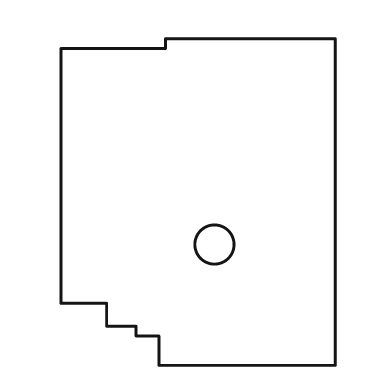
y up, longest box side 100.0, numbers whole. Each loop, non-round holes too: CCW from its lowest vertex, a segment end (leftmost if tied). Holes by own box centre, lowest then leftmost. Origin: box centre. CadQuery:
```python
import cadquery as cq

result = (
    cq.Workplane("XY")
    .moveTo(-12.0, -50.0)
    .lineTo(42.0, -50.0)
    .lineTo(42.0, 50.0)
    .lineTo(-10.0, 50.0)
    .lineTo(-10.0, 47.0)
    .lineTo(-42.0, 47.0)
    .lineTo(-42.0, -31.0)
    .lineTo(-28.0, -31.0)
    .lineTo(-28.0, -38.0)
    .lineTo(-19.0, -38.0)
    .lineTo(-19.0, -41.0)
    .lineTo(-12.0, -41.0)
    .close()
    .moveTo(5.0, -13.0)
    .circle(6.0)
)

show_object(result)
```